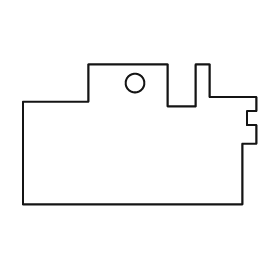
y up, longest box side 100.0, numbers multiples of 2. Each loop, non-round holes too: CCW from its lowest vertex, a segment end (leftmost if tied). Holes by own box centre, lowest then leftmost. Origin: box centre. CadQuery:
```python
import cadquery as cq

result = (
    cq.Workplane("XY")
    .moveTo(-50.0, -30.0)
    .lineTo(44.0, -30.0)
    .lineTo(44.0, -4.0)
    .lineTo(50.0, -4.0)
    .lineTo(50.0, 4.0)
    .lineTo(46.0, 4.0)
    .lineTo(46.0, 10.0)
    .lineTo(50.0, 10.0)
    .lineTo(50.0, 16.0)
    .lineTo(30.0, 16.0)
    .lineTo(30.0, 30.0)
    .lineTo(24.0, 30.0)
    .lineTo(24.0, 12.0)
    .lineTo(12.0, 12.0)
    .lineTo(12.0, 30.0)
    .lineTo(-22.0, 30.0)
    .lineTo(-22.0, 14.0)
    .lineTo(-50.0, 14.0)
    .close()
    .moveTo(-2.0, 22.0)
    .circle(4.0)
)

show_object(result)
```